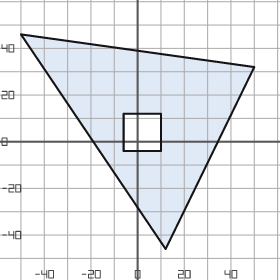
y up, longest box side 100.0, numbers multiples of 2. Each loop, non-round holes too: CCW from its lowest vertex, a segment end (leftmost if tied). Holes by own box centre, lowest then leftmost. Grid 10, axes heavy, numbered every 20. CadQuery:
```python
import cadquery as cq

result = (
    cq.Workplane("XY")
    .moveTo(12.0, -46.0)
    .lineTo(50.0, 32.0)
    .lineTo(-50.0, 46.0)
    .close()
    .moveTo(-6.0, -4.0)
    .lineTo(10.0, -4.0)
    .lineTo(10.0, 12.0)
    .lineTo(-6.0, 12.0)
    .close()
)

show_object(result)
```